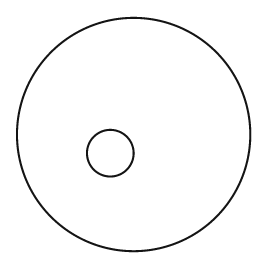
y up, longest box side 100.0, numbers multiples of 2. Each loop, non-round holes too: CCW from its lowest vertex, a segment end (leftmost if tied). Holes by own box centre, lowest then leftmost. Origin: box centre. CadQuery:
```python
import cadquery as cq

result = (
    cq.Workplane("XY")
    .moveTo(0.0, 0.0)
    .circle(50.0)
    .moveTo(-10.0, -8.0)
    .circle(10.0)
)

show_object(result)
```